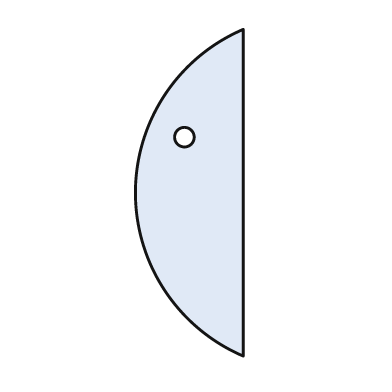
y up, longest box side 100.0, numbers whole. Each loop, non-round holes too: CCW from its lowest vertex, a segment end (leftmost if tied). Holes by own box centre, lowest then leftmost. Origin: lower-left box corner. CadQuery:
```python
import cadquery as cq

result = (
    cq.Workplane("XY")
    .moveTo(33.0, 0.0)
    .lineTo(33.0, 100.0)
    .threePointArc((0.0, 50.0), (33.0, 0.0))
    .close()
    .moveTo(15.0, 67.0)
    .circle(3.0)
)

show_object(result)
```